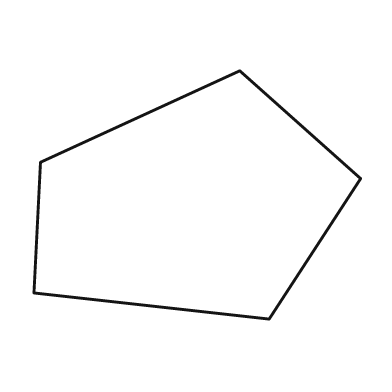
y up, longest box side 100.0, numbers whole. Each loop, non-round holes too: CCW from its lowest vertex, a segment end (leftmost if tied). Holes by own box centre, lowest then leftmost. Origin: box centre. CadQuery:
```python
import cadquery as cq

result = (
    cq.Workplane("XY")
    .moveTo(22.0, -38.0)
    .lineTo(50.0, 5.0)
    .lineTo(13.0, 38.0)
    .lineTo(-48.0, 10.0)
    .lineTo(-50.0, -30.0)
    .close()
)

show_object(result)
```